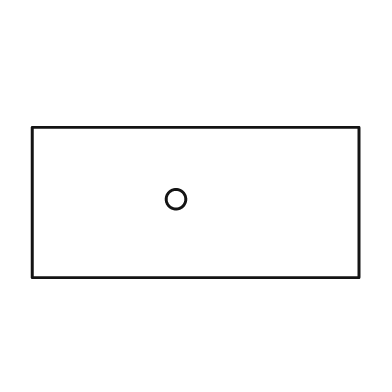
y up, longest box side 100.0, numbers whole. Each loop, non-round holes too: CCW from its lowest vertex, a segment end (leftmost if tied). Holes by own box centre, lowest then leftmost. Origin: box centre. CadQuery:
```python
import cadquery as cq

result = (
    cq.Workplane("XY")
    .moveTo(-50.0, -23.0)
    .lineTo(50.0, -23.0)
    .lineTo(50.0, 23.0)
    .lineTo(-50.0, 23.0)
    .close()
    .moveTo(-6.0, 1.0)
    .circle(3.0)
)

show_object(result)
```